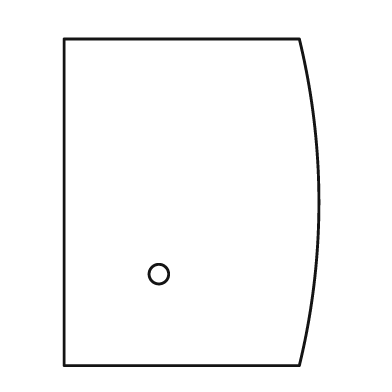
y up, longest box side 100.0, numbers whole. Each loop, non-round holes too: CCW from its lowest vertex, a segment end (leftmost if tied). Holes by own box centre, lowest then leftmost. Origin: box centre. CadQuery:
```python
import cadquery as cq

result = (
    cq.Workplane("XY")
    .moveTo(-39.0, -50.0)
    .lineTo(33.0, -50.0)
    .threePointArc((39.0, 0.0), (33.0, 50.0))
    .lineTo(-39.0, 50.0)
    .close()
    .moveTo(-10.0, -22.0)
    .circle(3.0)
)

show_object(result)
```